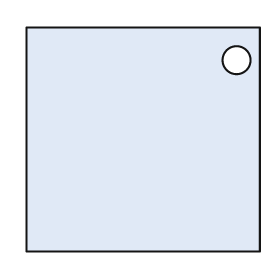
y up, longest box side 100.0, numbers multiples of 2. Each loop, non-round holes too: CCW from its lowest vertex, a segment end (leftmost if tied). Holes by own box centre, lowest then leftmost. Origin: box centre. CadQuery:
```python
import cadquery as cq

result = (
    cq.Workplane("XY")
    .moveTo(-50.0, -48.0)
    .lineTo(50.0, -48.0)
    .lineTo(50.0, 48.0)
    .lineTo(-50.0, 48.0)
    .close()
    .moveTo(40.0, 34.0)
    .circle(6.0)
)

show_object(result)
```